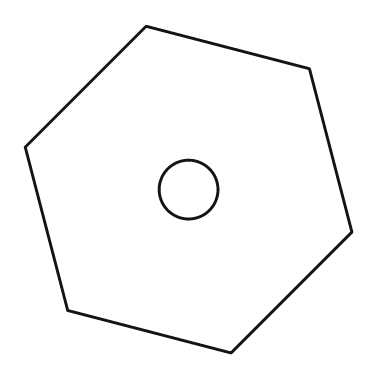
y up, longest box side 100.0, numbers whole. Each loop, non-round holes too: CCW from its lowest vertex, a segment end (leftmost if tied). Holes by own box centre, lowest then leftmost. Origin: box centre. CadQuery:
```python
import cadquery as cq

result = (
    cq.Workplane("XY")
    .moveTo(13.0, -50.0)
    .lineTo(50.0, -13.0)
    .lineTo(37.0, 37.0)
    .lineTo(-13.0, 50.0)
    .lineTo(-50.0, 13.0)
    .lineTo(-37.0, -37.0)
    .close()
    .moveTo(0.0, 0.0)
    .circle(9.0)
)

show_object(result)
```